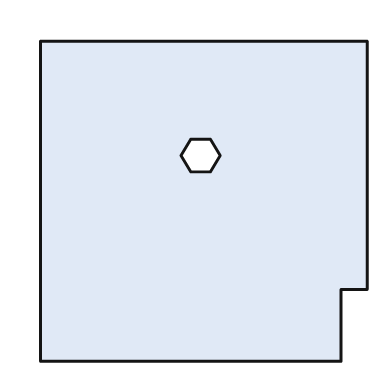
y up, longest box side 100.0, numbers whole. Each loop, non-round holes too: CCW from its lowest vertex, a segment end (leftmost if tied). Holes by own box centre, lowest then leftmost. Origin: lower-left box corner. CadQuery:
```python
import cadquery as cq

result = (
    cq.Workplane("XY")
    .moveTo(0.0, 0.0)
    .lineTo(92.0, 0.0)
    .lineTo(92.0, 22.0)
    .lineTo(100.0, 22.0)
    .lineTo(100.0, 98.0)
    .lineTo(0.0, 98.0)
    .close()
    .moveTo(46.0, 58.0)
    .lineTo(52.0, 58.0)
    .lineTo(55.0, 63.0)
    .lineTo(52.0, 68.0)
    .lineTo(46.0, 68.0)
    .lineTo(43.0, 63.0)
    .close()
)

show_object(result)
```